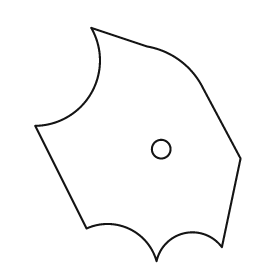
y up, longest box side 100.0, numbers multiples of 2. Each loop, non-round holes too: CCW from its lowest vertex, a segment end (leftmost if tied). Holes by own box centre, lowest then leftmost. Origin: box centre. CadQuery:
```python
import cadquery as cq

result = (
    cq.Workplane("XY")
    .moveTo(8.0, -50.0)
    .threePointArc((20.0, -38.0), (36.0, -44.0))
    .lineTo(44.0, -6.0)
    .lineTo(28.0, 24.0)
    .threePointArc((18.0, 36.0), (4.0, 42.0))
    .lineTo(-20.0, 50.0)
    .threePointArc((-20.0, 22.0), (-44.0, 8.0))
    .lineTo(-22.0, -36.0)
    .threePointArc((-4.0, -36.0), (8.0, -50.0))
    .close()
    .moveTo(10.0, -2.0)
    .circle(4.0)
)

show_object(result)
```